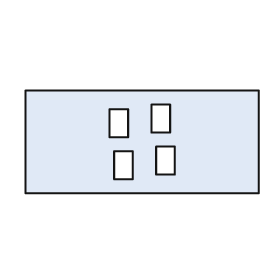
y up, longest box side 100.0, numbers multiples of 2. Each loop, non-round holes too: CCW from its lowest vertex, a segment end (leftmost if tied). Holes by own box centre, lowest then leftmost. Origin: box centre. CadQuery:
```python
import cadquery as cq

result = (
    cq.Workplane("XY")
    .moveTo(-50.0, -22.0)
    .lineTo(50.0, -22.0)
    .lineTo(50.0, 22.0)
    .lineTo(-50.0, 22.0)
    .close()
    .moveTo(-12.0, -16.0)
    .lineTo(-4.0, -16.0)
    .lineTo(-4.0, -4.0)
    .lineTo(-12.0, -4.0)
    .close()
    .moveTo(6.0, -14.0)
    .lineTo(14.0, -14.0)
    .lineTo(14.0, -2.0)
    .lineTo(6.0, -2.0)
    .close()
    .moveTo(-14.0, 2.0)
    .lineTo(-6.0, 2.0)
    .lineTo(-6.0, 14.0)
    .lineTo(-14.0, 14.0)
    .close()
    .moveTo(4.0, 4.0)
    .lineTo(12.0, 4.0)
    .lineTo(12.0, 16.0)
    .lineTo(4.0, 16.0)
    .close()
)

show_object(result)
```